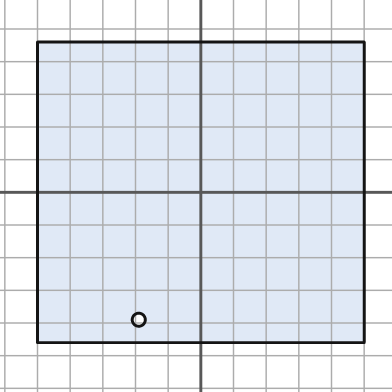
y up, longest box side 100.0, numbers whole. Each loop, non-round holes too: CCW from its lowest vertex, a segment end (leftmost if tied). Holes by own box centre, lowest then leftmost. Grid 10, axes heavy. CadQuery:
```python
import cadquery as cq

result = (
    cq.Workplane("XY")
    .moveTo(-50.0, -46.0)
    .lineTo(50.0, -46.0)
    .lineTo(50.0, 46.0)
    .lineTo(-50.0, 46.0)
    .close()
    .moveTo(-19.0, -39.0)
    .circle(2.0)
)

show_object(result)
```